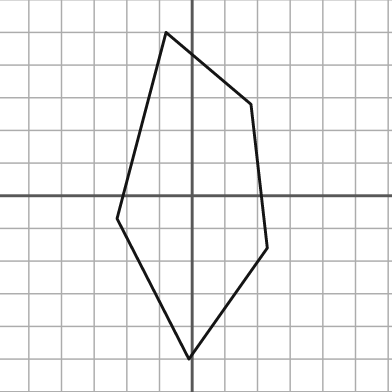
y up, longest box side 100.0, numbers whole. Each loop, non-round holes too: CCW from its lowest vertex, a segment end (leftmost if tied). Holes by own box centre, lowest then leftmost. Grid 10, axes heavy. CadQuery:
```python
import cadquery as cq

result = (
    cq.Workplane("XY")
    .moveTo(-1.0, -50.0)
    .lineTo(23.0, -16.0)
    .lineTo(18.0, 28.0)
    .lineTo(-8.0, 50.0)
    .lineTo(-23.0, -7.0)
    .close()
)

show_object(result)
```